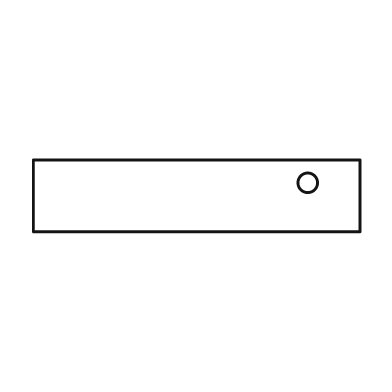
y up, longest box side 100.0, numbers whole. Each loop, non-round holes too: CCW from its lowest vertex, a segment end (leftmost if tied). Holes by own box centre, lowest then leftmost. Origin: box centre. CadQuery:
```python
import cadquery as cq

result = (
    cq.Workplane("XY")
    .moveTo(-50.0, -11.0)
    .lineTo(50.0, -11.0)
    .lineTo(50.0, 11.0)
    .lineTo(-50.0, 11.0)
    .close()
    .moveTo(34.0, 4.0)
    .circle(3.0)
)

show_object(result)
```